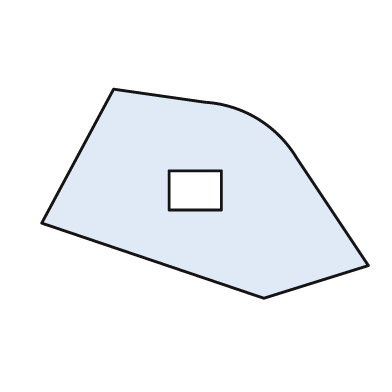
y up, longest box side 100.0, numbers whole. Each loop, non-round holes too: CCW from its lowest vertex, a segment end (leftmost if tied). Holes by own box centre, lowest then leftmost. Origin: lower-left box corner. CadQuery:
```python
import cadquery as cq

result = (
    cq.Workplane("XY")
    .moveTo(68.0, 0.0)
    .lineTo(100.0, 10.0)
    .lineTo(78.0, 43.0)
    .threePointArc((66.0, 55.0), (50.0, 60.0))
    .lineTo(22.0, 64.0)
    .lineTo(0.0, 23.0)
    .close()
    .moveTo(39.0, 27.0)
    .lineTo(55.0, 27.0)
    .lineTo(55.0, 39.0)
    .lineTo(39.0, 39.0)
    .close()
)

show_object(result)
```